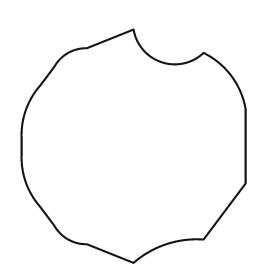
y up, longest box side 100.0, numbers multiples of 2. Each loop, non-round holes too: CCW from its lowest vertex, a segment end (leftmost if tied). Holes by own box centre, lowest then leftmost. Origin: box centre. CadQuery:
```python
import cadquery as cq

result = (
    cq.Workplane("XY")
    .moveTo(0.0, -50.0)
    .threePointArc((14.0, -42.0), (30.0, -40.0))
    .lineTo(48.0, -16.0)
    .lineTo(48.0, 16.0)
    .threePointArc((42.0, 30.0), (30.0, 40.0))
    .threePointArc((12.0, 36.0), (0.0, 50.0))
    .lineTo(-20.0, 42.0)
    .threePointArc((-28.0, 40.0), (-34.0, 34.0))
    .lineTo(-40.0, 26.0)
    .threePointArc((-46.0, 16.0), (-48.0, 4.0))
    .lineTo(-48.0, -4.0)
    .threePointArc((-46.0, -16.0), (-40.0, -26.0))
    .lineTo(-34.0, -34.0)
    .threePointArc((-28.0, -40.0), (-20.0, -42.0))
    .close()
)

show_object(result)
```